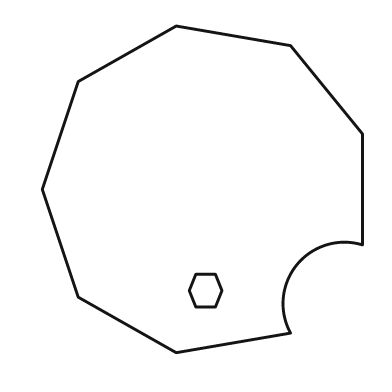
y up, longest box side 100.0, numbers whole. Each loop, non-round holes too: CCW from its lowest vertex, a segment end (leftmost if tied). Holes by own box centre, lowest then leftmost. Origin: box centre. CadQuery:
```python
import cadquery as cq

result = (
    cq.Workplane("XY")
    .moveTo(-8.0, -50.0)
    .lineTo(27.0, -44.0)
    .threePointArc((29.0, -23.0), (49.0, -17.0))
    .lineTo(49.0, 17.0)
    .lineTo(27.0, 44.0)
    .lineTo(-8.0, 50.0)
    .lineTo(-38.0, 33.0)
    .lineTo(-49.0, 0.0)
    .lineTo(-38.0, -33.0)
    .close()
    .moveTo(-2.0, -36.0)
    .lineTo(4.0, -36.0)
    .lineTo(6.0, -31.0)
    .lineTo(4.0, -26.0)
    .lineTo(-2.0, -26.0)
    .lineTo(-4.0, -31.0)
    .close()
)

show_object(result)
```